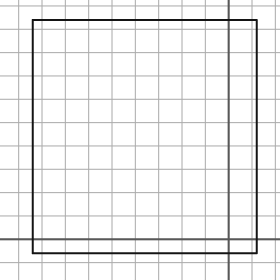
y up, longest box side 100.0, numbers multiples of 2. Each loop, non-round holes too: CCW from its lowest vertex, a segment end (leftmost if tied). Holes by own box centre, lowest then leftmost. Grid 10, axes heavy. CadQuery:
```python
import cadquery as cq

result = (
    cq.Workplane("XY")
    .moveTo(-84.0, -6.0)
    .lineTo(12.0, -6.0)
    .lineTo(12.0, 94.0)
    .lineTo(-84.0, 94.0)
    .close()
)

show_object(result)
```